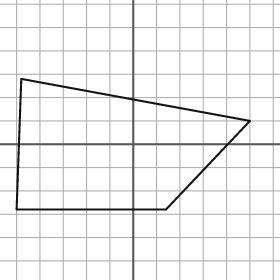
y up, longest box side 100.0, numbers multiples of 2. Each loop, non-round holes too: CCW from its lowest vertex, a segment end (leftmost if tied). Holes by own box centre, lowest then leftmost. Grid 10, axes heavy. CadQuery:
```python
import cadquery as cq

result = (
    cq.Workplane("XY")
    .moveTo(-50.0, -28.0)
    .lineTo(14.0, -28.0)
    .lineTo(50.0, 10.0)
    .lineTo(-48.0, 28.0)
    .close()
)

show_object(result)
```